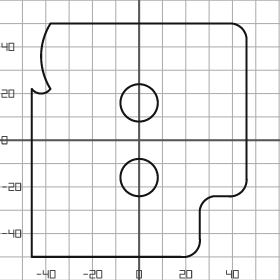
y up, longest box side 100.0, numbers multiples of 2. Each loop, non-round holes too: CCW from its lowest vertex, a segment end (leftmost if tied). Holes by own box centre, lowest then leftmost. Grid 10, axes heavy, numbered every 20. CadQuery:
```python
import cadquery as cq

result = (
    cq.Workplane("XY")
    .moveTo(-46.0, -50.0)
    .lineTo(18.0, -50.0)
    .threePointArc((24.0, -48.0), (26.0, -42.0))
    .lineTo(26.0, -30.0)
    .threePointArc((28.0, -26.0), (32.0, -24.0))
    .lineTo(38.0, -24.0)
    .threePointArc((44.0, -22.0), (46.0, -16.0))
    .lineTo(46.0, 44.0)
    .threePointArc((44.0, 48.0), (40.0, 50.0))
    .lineTo(-38.0, 50.0)
    .threePointArc((-42.0, 36.0), (-38.0, 22.0))
    .threePointArc((-42.0, 20.0), (-46.0, 22.0))
    .close()
    .moveTo(0.0, -16.0)
    .circle(8.0)
    .moveTo(0.0, 16.0)
    .circle(8.0)
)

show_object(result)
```